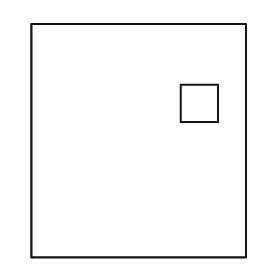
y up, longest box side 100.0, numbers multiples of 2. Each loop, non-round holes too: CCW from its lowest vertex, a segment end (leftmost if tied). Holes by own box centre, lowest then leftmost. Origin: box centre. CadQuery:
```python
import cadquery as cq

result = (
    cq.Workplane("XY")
    .moveTo(-46.0, -50.0)
    .lineTo(46.0, -50.0)
    .lineTo(46.0, 50.0)
    .lineTo(-46.0, 50.0)
    .close()
    .moveTo(18.0, 8.0)
    .lineTo(34.0, 8.0)
    .lineTo(34.0, 24.0)
    .lineTo(18.0, 24.0)
    .close()
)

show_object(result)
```